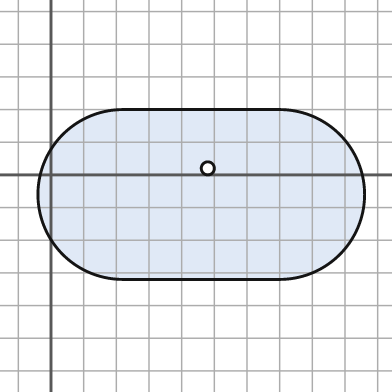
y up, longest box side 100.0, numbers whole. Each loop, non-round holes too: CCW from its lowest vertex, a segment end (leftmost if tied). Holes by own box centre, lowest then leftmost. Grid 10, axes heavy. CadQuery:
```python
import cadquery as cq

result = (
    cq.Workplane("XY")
    .moveTo(22.0, -32.0)
    .lineTo(70.0, -32.0)
    .threePointArc((96.0, -6.0), (70.0, 20.0))
    .lineTo(22.0, 20.0)
    .threePointArc((-4.0, -6.0), (22.0, -32.0))
    .close()
    .moveTo(48.0, 2.0)
    .circle(2.0)
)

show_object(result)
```